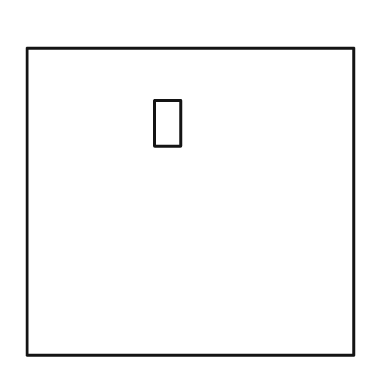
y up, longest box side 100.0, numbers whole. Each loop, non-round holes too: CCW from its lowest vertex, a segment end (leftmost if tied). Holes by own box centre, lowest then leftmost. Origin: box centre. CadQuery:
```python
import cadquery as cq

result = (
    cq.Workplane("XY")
    .moveTo(-50.0, -47.0)
    .lineTo(50.0, -47.0)
    .lineTo(50.0, 47.0)
    .lineTo(-50.0, 47.0)
    .close()
    .moveTo(-11.0, 17.0)
    .lineTo(-3.0, 17.0)
    .lineTo(-3.0, 31.0)
    .lineTo(-11.0, 31.0)
    .close()
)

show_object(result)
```